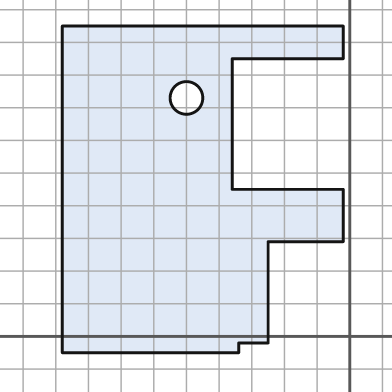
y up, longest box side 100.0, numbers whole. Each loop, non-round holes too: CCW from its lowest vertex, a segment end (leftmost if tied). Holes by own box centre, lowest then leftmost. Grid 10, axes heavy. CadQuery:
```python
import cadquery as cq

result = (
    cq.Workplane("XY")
    .moveTo(-88.0, -5.0)
    .lineTo(-34.0, -5.0)
    .lineTo(-34.0, -2.0)
    .lineTo(-25.0, -2.0)
    .lineTo(-25.0, 29.0)
    .lineTo(-2.0, 29.0)
    .lineTo(-2.0, 45.0)
    .lineTo(-36.0, 45.0)
    .lineTo(-36.0, 85.0)
    .lineTo(-2.0, 85.0)
    .lineTo(-2.0, 95.0)
    .lineTo(-88.0, 95.0)
    .close()
    .moveTo(-50.0, 73.0)
    .circle(5.0)
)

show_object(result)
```